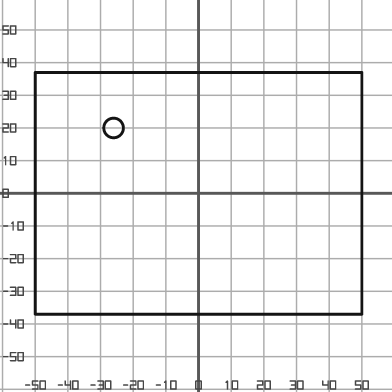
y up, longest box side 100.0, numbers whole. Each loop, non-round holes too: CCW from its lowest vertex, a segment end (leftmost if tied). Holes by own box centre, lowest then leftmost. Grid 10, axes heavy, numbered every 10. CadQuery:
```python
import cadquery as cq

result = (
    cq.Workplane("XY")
    .moveTo(-50.0, -37.0)
    .lineTo(50.0, -37.0)
    .lineTo(50.0, 37.0)
    .lineTo(-50.0, 37.0)
    .close()
    .moveTo(-26.0, 20.0)
    .circle(3.0)
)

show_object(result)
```